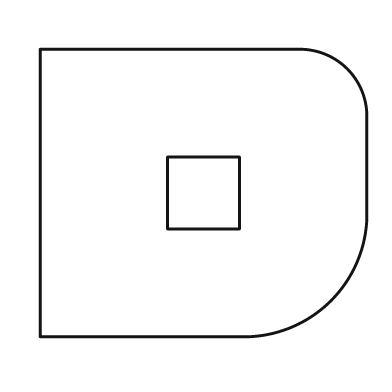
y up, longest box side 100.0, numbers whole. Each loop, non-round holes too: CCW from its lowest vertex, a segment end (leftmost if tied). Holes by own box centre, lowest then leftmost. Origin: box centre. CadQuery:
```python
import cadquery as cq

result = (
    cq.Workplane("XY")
    .moveTo(-50.0, -44.0)
    .lineTo(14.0, -44.0)
    .threePointArc((39.0, -33.0), (50.0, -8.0))
    .lineTo(50.0, 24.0)
    .threePointArc((44.0, 38.0), (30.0, 44.0))
    .lineTo(-50.0, 44.0)
    .close()
    .moveTo(-11.0, -11.0)
    .lineTo(11.0, -11.0)
    .lineTo(11.0, 11.0)
    .lineTo(-11.0, 11.0)
    .close()
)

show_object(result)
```